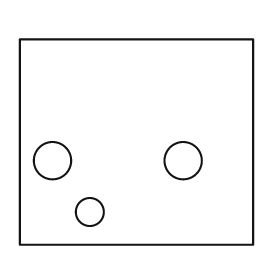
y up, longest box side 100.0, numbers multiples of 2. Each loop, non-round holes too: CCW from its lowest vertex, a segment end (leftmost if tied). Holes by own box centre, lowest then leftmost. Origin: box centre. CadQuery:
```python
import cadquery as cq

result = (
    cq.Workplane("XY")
    .moveTo(-50.0, -44.0)
    .lineTo(50.0, -44.0)
    .lineTo(50.0, 44.0)
    .lineTo(-50.0, 44.0)
    .close()
    .moveTo(-20.0, -30.0)
    .circle(6.0)
    .moveTo(-36.0, -8.0)
    .circle(8.0)
    .moveTo(20.0, -8.0)
    .circle(8.0)
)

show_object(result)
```